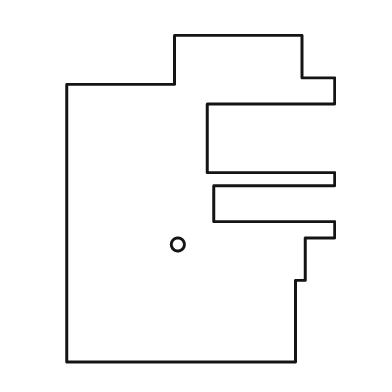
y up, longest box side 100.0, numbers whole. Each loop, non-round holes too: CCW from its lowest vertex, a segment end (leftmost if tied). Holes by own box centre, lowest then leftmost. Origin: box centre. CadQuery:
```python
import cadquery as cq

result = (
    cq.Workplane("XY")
    .moveTo(-41.0, -50.0)
    .lineTo(29.0, -50.0)
    .lineTo(29.0, -25.0)
    .lineTo(32.0, -25.0)
    .lineTo(32.0, -12.0)
    .lineTo(41.0, -12.0)
    .lineTo(41.0, -7.0)
    .lineTo(4.0, -7.0)
    .lineTo(4.0, 4.0)
    .lineTo(41.0, 4.0)
    .lineTo(41.0, 8.0)
    .lineTo(2.0, 8.0)
    .lineTo(2.0, 29.0)
    .lineTo(41.0, 29.0)
    .lineTo(41.0, 37.0)
    .lineTo(31.0, 37.0)
    .lineTo(31.0, 50.0)
    .lineTo(-8.0, 50.0)
    .lineTo(-8.0, 35.0)
    .lineTo(-41.0, 35.0)
    .close()
    .moveTo(-7.0, -14.0)
    .circle(2.0)
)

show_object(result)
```